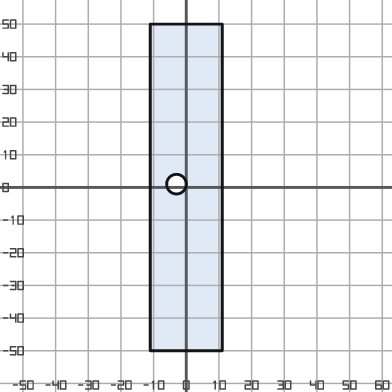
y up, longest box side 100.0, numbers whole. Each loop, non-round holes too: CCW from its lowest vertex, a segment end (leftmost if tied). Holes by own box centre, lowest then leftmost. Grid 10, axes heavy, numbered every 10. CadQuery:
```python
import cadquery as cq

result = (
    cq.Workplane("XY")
    .moveTo(-11.0, -50.0)
    .lineTo(11.0, -50.0)
    .lineTo(11.0, 50.0)
    .lineTo(-11.0, 50.0)
    .close()
    .moveTo(-3.0, 1.0)
    .circle(3.0)
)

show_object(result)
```